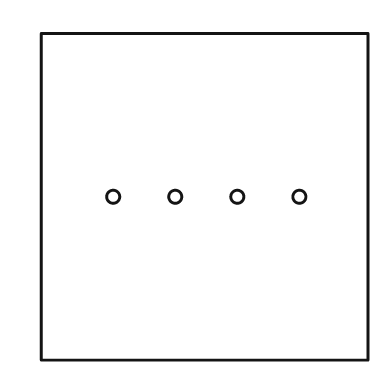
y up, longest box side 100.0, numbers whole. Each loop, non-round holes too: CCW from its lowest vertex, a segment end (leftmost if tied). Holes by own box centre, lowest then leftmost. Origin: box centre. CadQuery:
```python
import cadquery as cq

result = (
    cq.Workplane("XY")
    .moveTo(-50.0, -50.0)
    .lineTo(50.0, -50.0)
    .lineTo(50.0, 50.0)
    .lineTo(-50.0, 50.0)
    .close()
    .moveTo(-28.0, 0.0)
    .circle(2.0)
    .moveTo(-9.0, 0.0)
    .circle(2.0)
    .moveTo(10.0, 0.0)
    .circle(2.0)
    .moveTo(29.0, 0.0)
    .circle(2.0)
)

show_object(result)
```